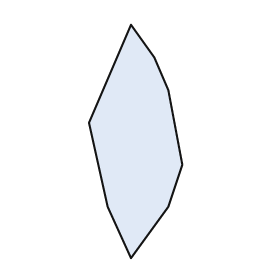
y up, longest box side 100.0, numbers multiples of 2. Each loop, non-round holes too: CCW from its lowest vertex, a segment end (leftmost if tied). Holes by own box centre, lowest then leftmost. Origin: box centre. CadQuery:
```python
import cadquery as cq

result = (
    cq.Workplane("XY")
    .moveTo(-2.0, -50.0)
    .lineTo(14.0, -28.0)
    .lineTo(20.0, -10.0)
    .lineTo(14.0, 22.0)
    .lineTo(8.0, 36.0)
    .lineTo(-2.0, 50.0)
    .lineTo(-20.0, 8.0)
    .lineTo(-12.0, -28.0)
    .close()
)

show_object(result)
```